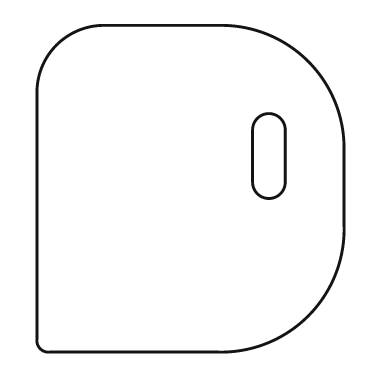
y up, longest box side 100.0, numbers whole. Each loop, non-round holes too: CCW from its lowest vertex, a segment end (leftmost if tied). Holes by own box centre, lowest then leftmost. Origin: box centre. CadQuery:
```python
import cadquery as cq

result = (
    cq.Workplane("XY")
    .moveTo(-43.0, -50.0)
    .lineTo(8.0, -50.0)
    .threePointArc((36.0, -39.0), (47.0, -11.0))
    .lineTo(47.0, 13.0)
    .threePointArc((36.0, 39.0), (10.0, 50.0))
    .lineTo(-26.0, 50.0)
    .threePointArc((-41.0, 44.0), (-47.0, 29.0))
    .lineTo(-47.0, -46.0)
    .threePointArc((-46.0, -49.0), (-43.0, -50.0))
    .close()
    .moveTo(19.0, 2.0)
    .threePointArc((24.0, -3.0), (29.0, 2.0))
    .lineTo(29.0, 18.0)
    .threePointArc((24.0, 23.0), (19.0, 18.0))
    .close()
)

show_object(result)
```